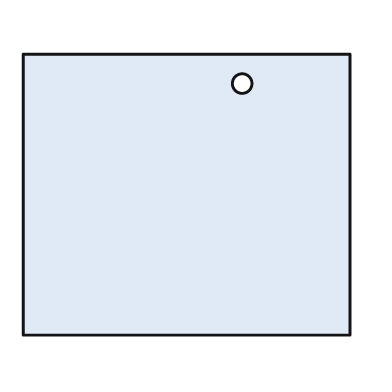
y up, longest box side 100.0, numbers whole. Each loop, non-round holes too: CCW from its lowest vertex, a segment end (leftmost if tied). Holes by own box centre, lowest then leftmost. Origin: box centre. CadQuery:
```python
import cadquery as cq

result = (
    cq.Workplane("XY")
    .moveTo(-50.0, -43.0)
    .lineTo(50.0, -43.0)
    .lineTo(50.0, 43.0)
    .lineTo(-50.0, 43.0)
    .close()
    .moveTo(17.0, 34.0)
    .circle(3.0)
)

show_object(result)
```